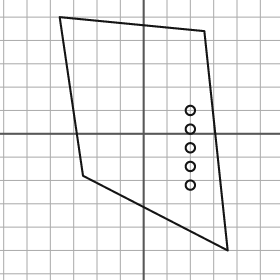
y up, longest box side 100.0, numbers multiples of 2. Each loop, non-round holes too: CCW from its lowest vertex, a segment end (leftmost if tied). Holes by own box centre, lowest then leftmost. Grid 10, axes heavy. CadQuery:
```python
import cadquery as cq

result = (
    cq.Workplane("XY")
    .moveTo(36.0, -50.0)
    .lineTo(26.0, 44.0)
    .lineTo(-36.0, 50.0)
    .lineTo(-26.0, -18.0)
    .close()
    .moveTo(20.0, -22.0)
    .circle(2.0)
    .moveTo(20.0, -14.0)
    .circle(2.0)
    .moveTo(20.0, -6.0)
    .circle(2.0)
    .moveTo(20.0, 2.0)
    .circle(2.0)
    .moveTo(20.0, 10.0)
    .circle(2.0)
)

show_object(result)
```